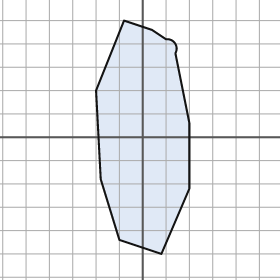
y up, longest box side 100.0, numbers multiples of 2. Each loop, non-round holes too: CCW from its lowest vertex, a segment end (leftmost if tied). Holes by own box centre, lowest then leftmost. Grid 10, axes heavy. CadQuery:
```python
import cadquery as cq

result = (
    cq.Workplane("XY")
    .moveTo(8.0, -50.0)
    .lineTo(20.0, -22.0)
    .lineTo(20.0, 6.0)
    .lineTo(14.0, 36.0)
    .threePointArc((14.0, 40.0), (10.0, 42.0))
    .lineTo(4.0, 46.0)
    .lineTo(-8.0, 50.0)
    .lineTo(-20.0, 20.0)
    .lineTo(-18.0, -18.0)
    .lineTo(-10.0, -44.0)
    .close()
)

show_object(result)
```